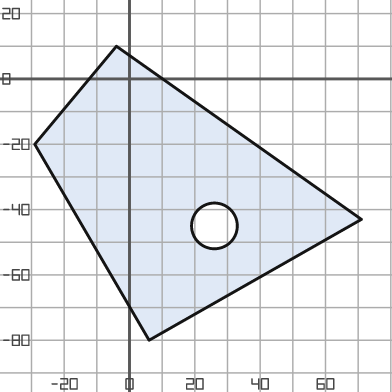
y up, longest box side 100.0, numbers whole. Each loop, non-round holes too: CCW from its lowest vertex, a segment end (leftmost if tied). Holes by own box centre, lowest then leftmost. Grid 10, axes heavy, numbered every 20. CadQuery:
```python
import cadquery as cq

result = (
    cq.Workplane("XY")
    .moveTo(6.0, -80.0)
    .lineTo(71.0, -43.0)
    .lineTo(-4.0, 10.0)
    .lineTo(-29.0, -20.0)
    .close()
    .moveTo(26.0, -45.0)
    .circle(7.0)
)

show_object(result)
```